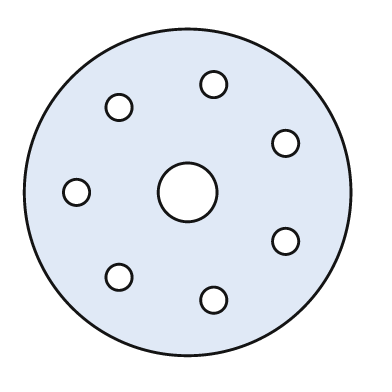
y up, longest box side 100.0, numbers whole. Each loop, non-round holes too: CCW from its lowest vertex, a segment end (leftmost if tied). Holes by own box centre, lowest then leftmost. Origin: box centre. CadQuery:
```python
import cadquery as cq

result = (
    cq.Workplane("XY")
    .moveTo(0.0, 0.0)
    .circle(50.0)
    .moveTo(8.0, -33.0)
    .circle(4.0)
    .moveTo(-21.0, -26.0)
    .circle(4.0)
    .moveTo(30.0, -15.0)
    .circle(4.0)
    .moveTo(-34.0, 0.0)
    .circle(4.0)
    .moveTo(0.0, 0.0)
    .circle(9.0)
    .moveTo(30.0, 15.0)
    .circle(4.0)
    .moveTo(-21.0, 26.0)
    .circle(4.0)
    .moveTo(8.0, 33.0)
    .circle(4.0)
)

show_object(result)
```